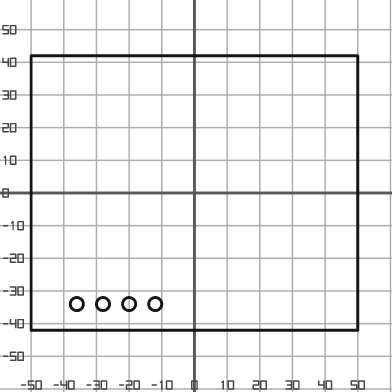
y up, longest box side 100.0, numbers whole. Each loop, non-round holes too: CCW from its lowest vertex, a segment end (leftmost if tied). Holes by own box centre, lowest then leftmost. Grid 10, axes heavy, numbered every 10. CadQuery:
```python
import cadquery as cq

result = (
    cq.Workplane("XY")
    .moveTo(-50.0, -42.0)
    .lineTo(50.0, -42.0)
    .lineTo(50.0, 42.0)
    .lineTo(-50.0, 42.0)
    .close()
    .moveTo(-36.0, -34.0)
    .circle(2.0)
    .moveTo(-28.0, -34.0)
    .circle(2.0)
    .moveTo(-20.0, -34.0)
    .circle(2.0)
    .moveTo(-12.0, -34.0)
    .circle(2.0)
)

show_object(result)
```